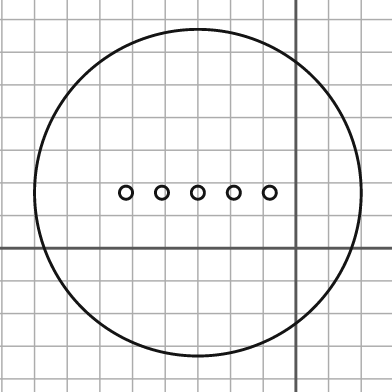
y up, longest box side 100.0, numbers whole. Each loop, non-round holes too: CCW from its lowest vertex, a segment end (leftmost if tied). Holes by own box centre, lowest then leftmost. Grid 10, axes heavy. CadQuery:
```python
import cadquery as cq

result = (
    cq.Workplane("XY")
    .moveTo(-30.0, 17.0)
    .circle(50.0)
    .moveTo(-52.0, 17.0)
    .circle(2.0)
    .moveTo(-41.0, 17.0)
    .circle(2.0)
    .moveTo(-30.0, 17.0)
    .circle(2.0)
    .moveTo(-19.0, 17.0)
    .circle(2.0)
    .moveTo(-8.0, 17.0)
    .circle(2.0)
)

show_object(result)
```